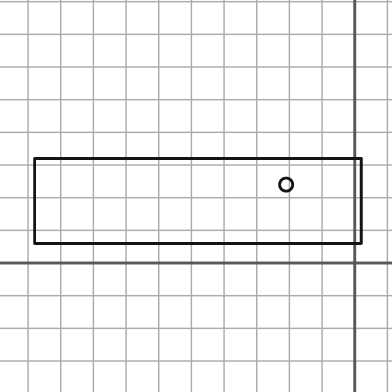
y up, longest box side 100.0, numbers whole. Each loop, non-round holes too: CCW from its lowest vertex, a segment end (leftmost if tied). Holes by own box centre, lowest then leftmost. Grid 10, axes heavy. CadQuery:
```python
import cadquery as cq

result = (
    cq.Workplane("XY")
    .moveTo(-98.0, 6.0)
    .lineTo(2.0, 6.0)
    .lineTo(2.0, 32.0)
    .lineTo(-98.0, 32.0)
    .close()
    .moveTo(-21.0, 24.0)
    .circle(2.0)
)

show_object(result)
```